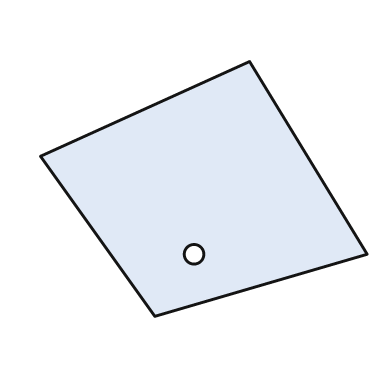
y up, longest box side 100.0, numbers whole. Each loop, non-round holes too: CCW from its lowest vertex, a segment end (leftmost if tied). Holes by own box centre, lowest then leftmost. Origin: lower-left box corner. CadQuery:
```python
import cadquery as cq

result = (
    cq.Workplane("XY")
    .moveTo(35.0, 0.0)
    .lineTo(100.0, 19.0)
    .lineTo(64.0, 78.0)
    .lineTo(0.0, 49.0)
    .close()
    .moveTo(47.0, 19.0)
    .circle(3.0)
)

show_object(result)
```